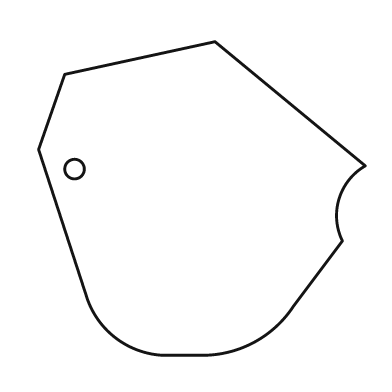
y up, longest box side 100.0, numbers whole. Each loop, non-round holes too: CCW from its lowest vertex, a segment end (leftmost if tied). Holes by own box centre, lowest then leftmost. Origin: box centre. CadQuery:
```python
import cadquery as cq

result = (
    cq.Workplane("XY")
    .moveTo(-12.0, -48.0)
    .lineTo(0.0, -48.0)
    .threePointArc((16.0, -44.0), (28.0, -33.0))
    .lineTo(43.0, -13.0)
    .threePointArc((42.0, 0.0), (50.0, 10.0))
    .lineTo(4.0, 48.0)
    .lineTo(-42.0, 38.0)
    .lineTo(-50.0, 15.0)
    .lineTo(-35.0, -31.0)
    .threePointArc((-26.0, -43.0), (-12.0, -48.0))
    .close()
    .moveTo(-39.0, 9.0)
    .circle(3.0)
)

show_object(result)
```